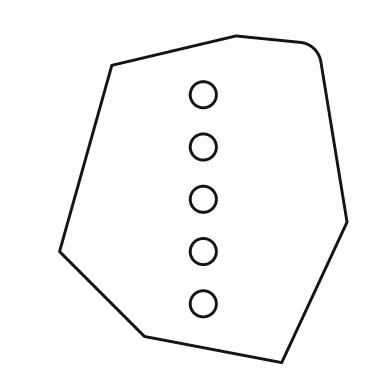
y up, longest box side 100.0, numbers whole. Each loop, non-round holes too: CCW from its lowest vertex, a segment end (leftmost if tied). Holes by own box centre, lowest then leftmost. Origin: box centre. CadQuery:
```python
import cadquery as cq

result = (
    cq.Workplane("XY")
    .moveTo(24.0, -50.0)
    .lineTo(44.0, -7.0)
    .lineTo(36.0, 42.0)
    .threePointArc((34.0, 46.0), (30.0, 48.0))
    .lineTo(10.0, 50.0)
    .lineTo(-28.0, 41.0)
    .lineTo(-44.0, -16.0)
    .lineTo(-18.0, -42.0)
    .close()
    .moveTo(0.0, -32.0)
    .circle(4.0)
    .moveTo(0.0, -16.0)
    .circle(4.0)
    .moveTo(0.0, 0.0)
    .circle(4.0)
    .moveTo(0.0, 16.0)
    .circle(4.0)
    .moveTo(0.0, 32.0)
    .circle(4.0)
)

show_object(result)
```